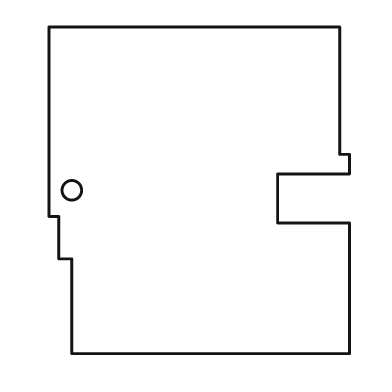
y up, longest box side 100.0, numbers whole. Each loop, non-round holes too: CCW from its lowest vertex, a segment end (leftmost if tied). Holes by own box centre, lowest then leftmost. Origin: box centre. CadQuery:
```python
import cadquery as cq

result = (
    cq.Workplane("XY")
    .moveTo(-39.0, -50.0)
    .lineTo(46.0, -50.0)
    .lineTo(46.0, -10.0)
    .lineTo(24.0, -10.0)
    .lineTo(24.0, 5.0)
    .lineTo(46.0, 5.0)
    .lineTo(46.0, 11.0)
    .lineTo(43.0, 11.0)
    .lineTo(43.0, 50.0)
    .lineTo(-46.0, 50.0)
    .lineTo(-46.0, -8.0)
    .lineTo(-43.0, -8.0)
    .lineTo(-43.0, -21.0)
    .lineTo(-39.0, -21.0)
    .close()
    .moveTo(-39.0, 0.0)
    .circle(3.0)
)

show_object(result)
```